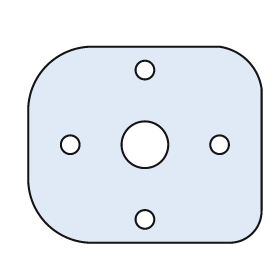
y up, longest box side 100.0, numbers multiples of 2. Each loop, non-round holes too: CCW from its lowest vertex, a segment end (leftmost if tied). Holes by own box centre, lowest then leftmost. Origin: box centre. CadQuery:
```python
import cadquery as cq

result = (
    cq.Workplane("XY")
    .moveTo(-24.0, -42.0)
    .lineTo(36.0, -42.0)
    .threePointArc((46.0, -38.0), (50.0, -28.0))
    .lineTo(50.0, 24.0)
    .threePointArc((44.0, 36.0), (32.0, 42.0))
    .lineTo(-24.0, 42.0)
    .threePointArc((-42.0, 34.0), (-50.0, 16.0))
    .lineTo(-50.0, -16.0)
    .threePointArc((-42.0, -34.0), (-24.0, -42.0))
    .close()
    .moveTo(0.0, -32.0)
    .circle(4.0)
    .moveTo(-32.0, 0.0)
    .circle(4.0)
    .moveTo(0.0, 0.0)
    .circle(10.0)
    .moveTo(32.0, 0.0)
    .circle(4.0)
    .moveTo(0.0, 32.0)
    .circle(4.0)
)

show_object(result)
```